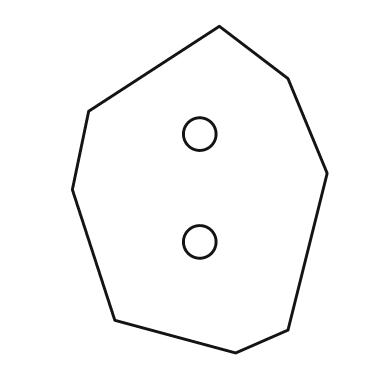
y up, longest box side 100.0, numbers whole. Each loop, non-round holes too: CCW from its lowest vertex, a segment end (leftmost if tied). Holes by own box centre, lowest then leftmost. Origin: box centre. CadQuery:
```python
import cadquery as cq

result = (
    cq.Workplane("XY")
    .moveTo(11.0, -50.0)
    .lineTo(27.0, -43.0)
    .lineTo(39.0, 5.0)
    .lineTo(27.0, 34.0)
    .lineTo(6.0, 50.0)
    .lineTo(-34.0, 24.0)
    .lineTo(-39.0, 0.0)
    .lineTo(-26.0, -40.0)
    .close()
    .moveTo(0.0, -16.0)
    .circle(5.0)
    .moveTo(0.0, 17.0)
    .circle(5.0)
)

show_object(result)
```